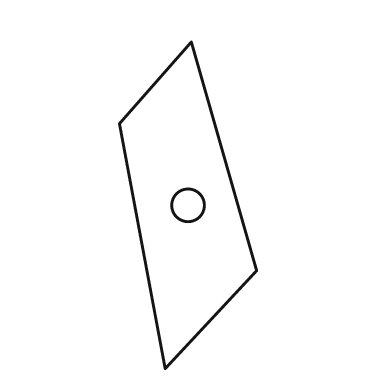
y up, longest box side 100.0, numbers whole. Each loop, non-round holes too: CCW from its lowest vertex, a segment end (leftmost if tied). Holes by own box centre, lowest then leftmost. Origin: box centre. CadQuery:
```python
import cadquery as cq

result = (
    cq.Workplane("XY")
    .moveTo(-7.0, -50.0)
    .lineTo(21.0, -20.0)
    .lineTo(1.0, 50.0)
    .lineTo(-21.0, 25.0)
    .close()
    .moveTo(0.0, 0.0)
    .circle(5.0)
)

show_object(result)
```